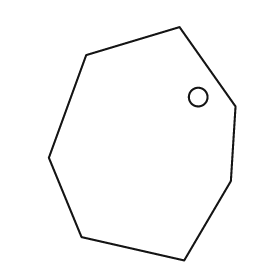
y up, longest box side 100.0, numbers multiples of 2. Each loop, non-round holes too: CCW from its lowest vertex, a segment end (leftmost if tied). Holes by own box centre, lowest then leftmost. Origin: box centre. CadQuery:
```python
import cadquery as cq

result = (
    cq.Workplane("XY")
    .moveTo(18.0, -50.0)
    .lineTo(38.0, -16.0)
    .lineTo(40.0, 16.0)
    .lineTo(16.0, 50.0)
    .lineTo(-24.0, 38.0)
    .lineTo(-40.0, -6.0)
    .lineTo(-26.0, -40.0)
    .close()
    .moveTo(24.0, 20.0)
    .circle(4.0)
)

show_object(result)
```